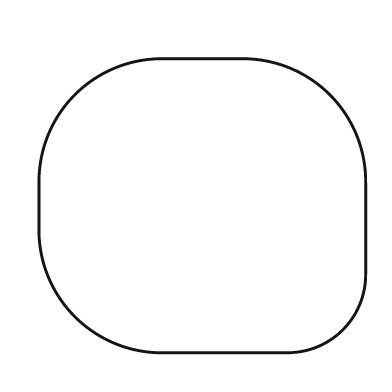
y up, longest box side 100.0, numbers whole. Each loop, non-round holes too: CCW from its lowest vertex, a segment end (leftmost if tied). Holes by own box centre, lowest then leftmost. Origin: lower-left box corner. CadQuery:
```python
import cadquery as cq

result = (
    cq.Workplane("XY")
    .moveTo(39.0, 0.0)
    .lineTo(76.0, 0.0)
    .threePointArc((93.0, 7.0), (100.0, 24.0))
    .lineTo(100.0, 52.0)
    .threePointArc((89.0, 79.0), (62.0, 90.0))
    .lineTo(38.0, 90.0)
    .threePointArc((11.0, 79.0), (0.0, 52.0))
    .lineTo(0.0, 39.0)
    .threePointArc((11.0, 11.0), (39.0, 0.0))
    .close()
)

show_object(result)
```